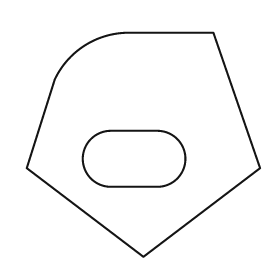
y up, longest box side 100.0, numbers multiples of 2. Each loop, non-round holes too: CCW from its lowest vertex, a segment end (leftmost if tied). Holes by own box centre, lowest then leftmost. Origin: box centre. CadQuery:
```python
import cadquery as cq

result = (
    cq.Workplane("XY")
    .moveTo(0.0, -48.0)
    .lineTo(50.0, -10.0)
    .lineTo(30.0, 48.0)
    .lineTo(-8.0, 48.0)
    .threePointArc((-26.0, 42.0), (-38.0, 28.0))
    .lineTo(-50.0, -10.0)
    .close()
    .moveTo(-14.0, -18.0)
    .lineTo(6.0, -18.0)
    .threePointArc((18.0, -6.0), (6.0, 6.0))
    .lineTo(-14.0, 6.0)
    .threePointArc((-26.0, -6.0), (-14.0, -18.0))
    .close()
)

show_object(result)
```